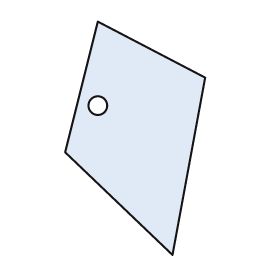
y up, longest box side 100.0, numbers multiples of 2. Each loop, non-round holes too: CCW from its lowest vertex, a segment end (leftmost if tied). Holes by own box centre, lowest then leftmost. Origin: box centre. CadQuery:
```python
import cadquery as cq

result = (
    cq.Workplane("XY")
    .moveTo(16.0, -50.0)
    .lineTo(30.0, 26.0)
    .lineTo(-16.0, 50.0)
    .lineTo(-30.0, -6.0)
    .close()
    .moveTo(-16.0, 14.0)
    .circle(4.0)
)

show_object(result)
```